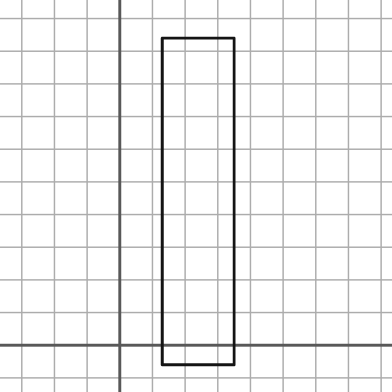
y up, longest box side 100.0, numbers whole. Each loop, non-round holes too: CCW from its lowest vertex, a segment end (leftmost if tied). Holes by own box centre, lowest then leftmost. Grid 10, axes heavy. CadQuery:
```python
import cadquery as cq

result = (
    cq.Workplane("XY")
    .moveTo(13.0, -6.0)
    .lineTo(35.0, -6.0)
    .lineTo(35.0, 94.0)
    .lineTo(13.0, 94.0)
    .close()
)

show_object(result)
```